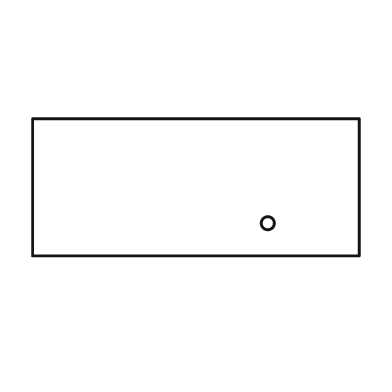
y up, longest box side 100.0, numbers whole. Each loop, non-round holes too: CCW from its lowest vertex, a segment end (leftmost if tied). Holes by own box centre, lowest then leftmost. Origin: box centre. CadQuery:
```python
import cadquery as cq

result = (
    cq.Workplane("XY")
    .moveTo(-50.0, -21.0)
    .lineTo(50.0, -21.0)
    .lineTo(50.0, 21.0)
    .lineTo(-50.0, 21.0)
    .close()
    .moveTo(22.0, -11.0)
    .circle(2.0)
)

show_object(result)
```